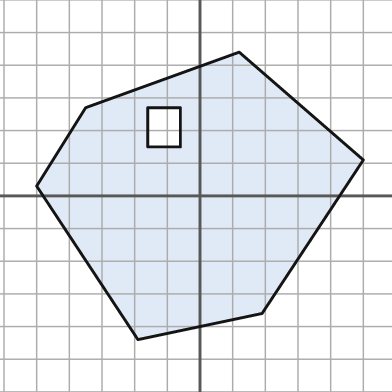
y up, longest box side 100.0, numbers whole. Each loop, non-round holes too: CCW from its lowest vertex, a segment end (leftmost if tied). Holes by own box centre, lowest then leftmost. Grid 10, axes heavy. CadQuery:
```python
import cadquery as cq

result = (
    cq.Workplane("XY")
    .moveTo(-19.0, -44.0)
    .lineTo(19.0, -36.0)
    .lineTo(50.0, 11.0)
    .lineTo(12.0, 44.0)
    .lineTo(-35.0, 27.0)
    .lineTo(-50.0, 3.0)
    .close()
    .moveTo(-16.0, 15.0)
    .lineTo(-6.0, 15.0)
    .lineTo(-6.0, 27.0)
    .lineTo(-16.0, 27.0)
    .close()
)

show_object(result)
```